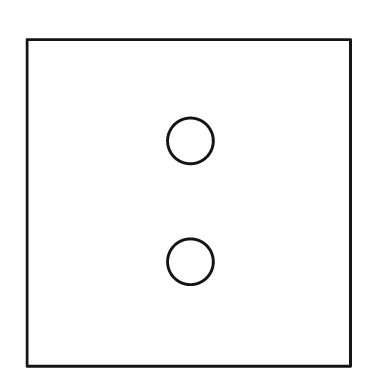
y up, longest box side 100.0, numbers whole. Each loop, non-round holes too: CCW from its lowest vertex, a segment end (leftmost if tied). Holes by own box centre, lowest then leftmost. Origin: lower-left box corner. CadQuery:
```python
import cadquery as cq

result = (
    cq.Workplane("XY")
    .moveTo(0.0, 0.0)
    .lineTo(99.0, 0.0)
    .lineTo(99.0, 100.0)
    .lineTo(0.0, 100.0)
    .close()
    .moveTo(50.0, 32.0)
    .circle(7.0)
    .moveTo(50.0, 69.0)
    .circle(7.0)
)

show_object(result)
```